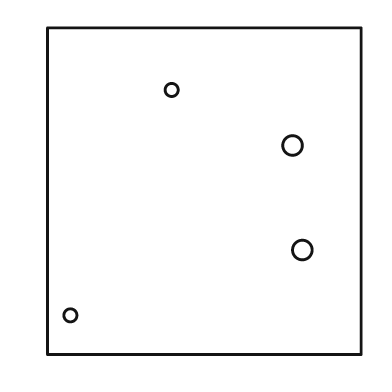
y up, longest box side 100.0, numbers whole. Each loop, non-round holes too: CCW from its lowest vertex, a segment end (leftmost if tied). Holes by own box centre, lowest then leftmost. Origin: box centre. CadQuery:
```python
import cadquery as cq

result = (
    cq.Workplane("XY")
    .moveTo(-48.0, -50.0)
    .lineTo(48.0, -50.0)
    .lineTo(48.0, 50.0)
    .lineTo(-48.0, 50.0)
    .close()
    .moveTo(-41.0, -38.0)
    .circle(2.0)
    .moveTo(30.0, -18.0)
    .circle(3.0)
    .moveTo(27.0, 14.0)
    .circle(3.0)
    .moveTo(-10.0, 31.0)
    .circle(2.0)
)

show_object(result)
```